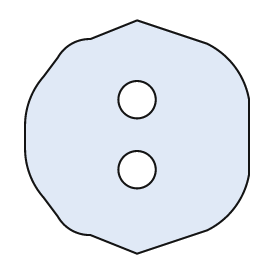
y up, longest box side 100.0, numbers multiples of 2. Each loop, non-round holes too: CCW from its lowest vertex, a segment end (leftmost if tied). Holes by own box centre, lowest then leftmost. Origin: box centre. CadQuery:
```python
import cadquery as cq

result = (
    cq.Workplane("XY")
    .moveTo(0.0, -50.0)
    .lineTo(30.0, -40.0)
    .threePointArc((42.0, -30.0), (48.0, -16.0))
    .lineTo(48.0, 16.0)
    .threePointArc((42.0, 30.0), (30.0, 40.0))
    .lineTo(0.0, 50.0)
    .lineTo(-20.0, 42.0)
    .threePointArc((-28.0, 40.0), (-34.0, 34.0))
    .lineTo(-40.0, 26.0)
    .threePointArc((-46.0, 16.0), (-48.0, 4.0))
    .lineTo(-48.0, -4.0)
    .threePointArc((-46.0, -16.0), (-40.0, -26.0))
    .lineTo(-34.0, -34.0)
    .threePointArc((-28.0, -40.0), (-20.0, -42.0))
    .close()
    .moveTo(0.0, -14.0)
    .circle(8.0)
    .moveTo(0.0, 16.0)
    .circle(8.0)
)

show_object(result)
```